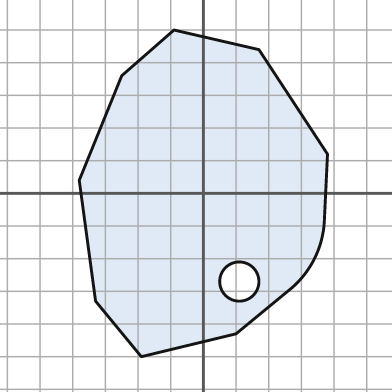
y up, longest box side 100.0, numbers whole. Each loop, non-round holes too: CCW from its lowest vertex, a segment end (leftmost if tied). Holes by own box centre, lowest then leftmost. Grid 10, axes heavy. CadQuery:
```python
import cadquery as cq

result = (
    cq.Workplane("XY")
    .moveTo(-19.0, -50.0)
    .lineTo(10.0, -43.0)
    .lineTo(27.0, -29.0)
    .threePointArc((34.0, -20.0), (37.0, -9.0))
    .lineTo(38.0, 12.0)
    .lineTo(17.0, 44.0)
    .lineTo(-9.0, 50.0)
    .lineTo(-25.0, 36.0)
    .lineTo(-38.0, 4.0)
    .lineTo(-33.0, -33.0)
    .close()
    .moveTo(11.0, -27.0)
    .circle(6.0)
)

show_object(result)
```